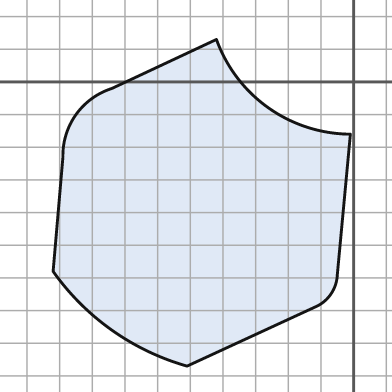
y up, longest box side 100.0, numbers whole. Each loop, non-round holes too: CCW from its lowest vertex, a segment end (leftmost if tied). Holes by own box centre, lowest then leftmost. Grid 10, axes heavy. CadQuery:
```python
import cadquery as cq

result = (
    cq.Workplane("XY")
    .moveTo(-51.0, -87.0)
    .lineTo(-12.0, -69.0)
    .threePointArc((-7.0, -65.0), (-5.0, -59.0))
    .lineTo(-1.0, -16.0)
    .threePointArc((-26.0, -8.0), (-42.0, 13.0))
    .lineTo(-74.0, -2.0)
    .threePointArc((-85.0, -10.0), (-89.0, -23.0))
    .lineTo(-92.0, -58.0)
    .threePointArc((-74.0, -76.0), (-51.0, -87.0))
    .close()
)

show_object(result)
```